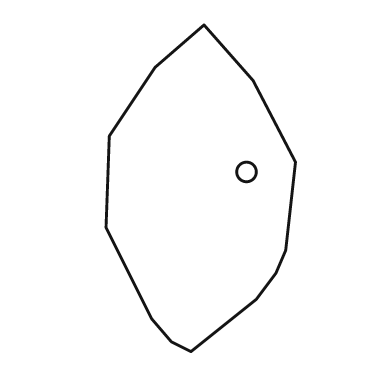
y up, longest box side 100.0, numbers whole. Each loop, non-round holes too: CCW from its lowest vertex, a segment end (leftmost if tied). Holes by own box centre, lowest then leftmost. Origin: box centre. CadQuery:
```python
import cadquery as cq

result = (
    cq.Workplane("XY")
    .moveTo(-3.0, -50.0)
    .lineTo(17.0, -34.0)
    .lineTo(23.0, -26.0)
    .lineTo(26.0, -19.0)
    .lineTo(29.0, 8.0)
    .lineTo(16.0, 33.0)
    .lineTo(1.0, 50.0)
    .lineTo(-14.0, 37.0)
    .lineTo(-28.0, 16.0)
    .lineTo(-29.0, -12.0)
    .lineTo(-15.0, -40.0)
    .lineTo(-9.0, -47.0)
    .close()
    .moveTo(14.0, 5.0)
    .circle(3.0)
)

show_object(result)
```